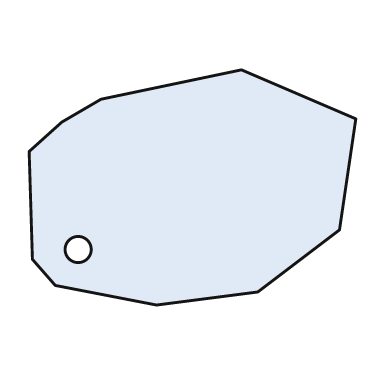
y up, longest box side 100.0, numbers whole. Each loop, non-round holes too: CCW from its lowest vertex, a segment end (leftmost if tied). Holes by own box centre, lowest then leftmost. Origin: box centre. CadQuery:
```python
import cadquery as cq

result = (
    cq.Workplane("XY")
    .moveTo(-11.0, -36.0)
    .lineTo(20.0, -32.0)
    .lineTo(45.0, -13.0)
    .lineTo(50.0, 21.0)
    .lineTo(15.0, 36.0)
    .lineTo(-28.0, 27.0)
    .lineTo(-40.0, 20.0)
    .lineTo(-50.0, 11.0)
    .lineTo(-49.0, -22.0)
    .lineTo(-42.0, -30.0)
    .close()
    .moveTo(-35.0, -19.0)
    .circle(4.0)
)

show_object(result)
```